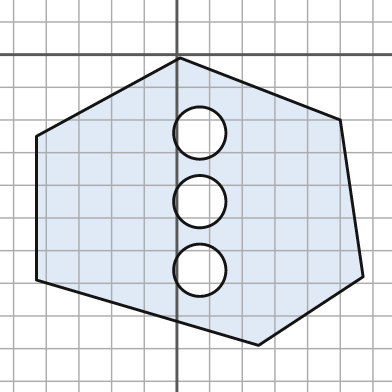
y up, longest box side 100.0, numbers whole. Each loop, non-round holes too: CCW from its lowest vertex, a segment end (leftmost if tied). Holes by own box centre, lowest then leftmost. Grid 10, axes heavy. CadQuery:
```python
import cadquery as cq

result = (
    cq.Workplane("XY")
    .moveTo(25.0, -89.0)
    .lineTo(57.0, -68.0)
    .lineTo(50.0, -20.0)
    .lineTo(1.0, -1.0)
    .lineTo(-43.0, -25.0)
    .lineTo(-43.0, -69.0)
    .close()
    .moveTo(7.0, -66.0)
    .circle(8.0)
    .moveTo(7.0, -45.0)
    .circle(8.0)
    .moveTo(7.0, -24.0)
    .circle(8.0)
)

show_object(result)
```